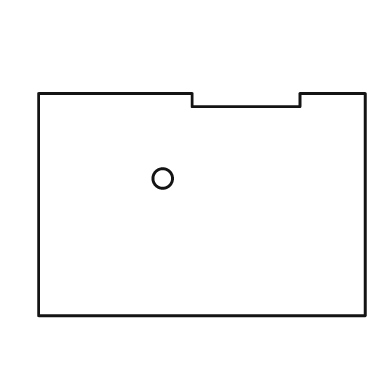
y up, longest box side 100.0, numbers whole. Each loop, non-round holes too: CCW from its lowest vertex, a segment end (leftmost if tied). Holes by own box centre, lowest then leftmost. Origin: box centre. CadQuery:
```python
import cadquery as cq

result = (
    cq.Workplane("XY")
    .moveTo(-50.0, -34.0)
    .lineTo(50.0, -34.0)
    .lineTo(50.0, 34.0)
    .lineTo(30.0, 34.0)
    .lineTo(30.0, 30.0)
    .lineTo(-3.0, 30.0)
    .lineTo(-3.0, 34.0)
    .lineTo(-50.0, 34.0)
    .close()
    .moveTo(-12.0, 8.0)
    .circle(3.0)
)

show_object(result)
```